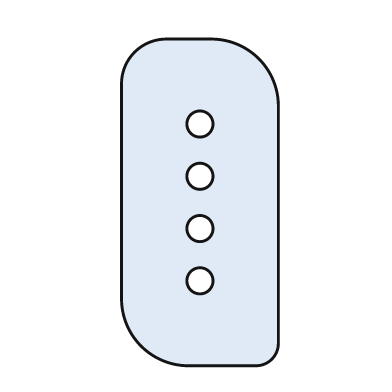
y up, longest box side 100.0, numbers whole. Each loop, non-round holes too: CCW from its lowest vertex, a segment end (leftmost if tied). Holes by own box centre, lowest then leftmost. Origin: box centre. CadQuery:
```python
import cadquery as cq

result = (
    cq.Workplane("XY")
    .moveTo(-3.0, -50.0)
    .lineTo(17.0, -50.0)
    .threePointArc((22.0, -48.0), (24.0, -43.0))
    .lineTo(24.0, 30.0)
    .threePointArc((18.0, 44.0), (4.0, 50.0))
    .lineTo(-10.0, 50.0)
    .threePointArc((-20.0, 46.0), (-24.0, 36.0))
    .lineTo(-24.0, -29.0)
    .threePointArc((-18.0, -44.0), (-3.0, -50.0))
    .close()
    .moveTo(0.0, -24.0)
    .circle(4.0)
    .moveTo(0.0, -8.0)
    .circle(4.0)
    .moveTo(0.0, 8.0)
    .circle(4.0)
    .moveTo(0.0, 24.0)
    .circle(4.0)
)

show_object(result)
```